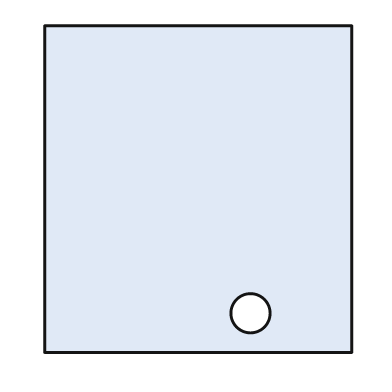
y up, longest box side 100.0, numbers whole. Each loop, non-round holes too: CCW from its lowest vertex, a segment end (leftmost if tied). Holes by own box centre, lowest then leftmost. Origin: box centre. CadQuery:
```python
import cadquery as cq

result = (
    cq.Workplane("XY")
    .moveTo(-47.0, -50.0)
    .lineTo(47.0, -50.0)
    .lineTo(47.0, 50.0)
    .lineTo(-47.0, 50.0)
    .close()
    .moveTo(16.0, -38.0)
    .circle(6.0)
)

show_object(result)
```